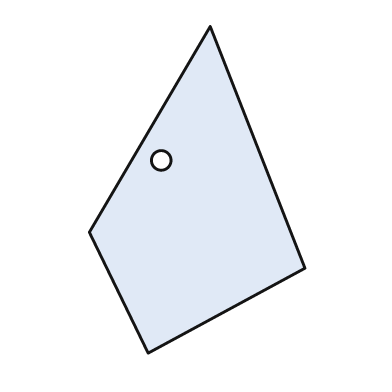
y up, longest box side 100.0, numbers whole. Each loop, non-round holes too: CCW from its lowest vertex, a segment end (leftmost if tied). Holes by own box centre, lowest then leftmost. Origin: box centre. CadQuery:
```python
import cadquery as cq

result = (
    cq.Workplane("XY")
    .moveTo(-15.0, -50.0)
    .lineTo(33.0, -24.0)
    .lineTo(4.0, 50.0)
    .lineTo(-33.0, -13.0)
    .close()
    .moveTo(-11.0, 9.0)
    .circle(3.0)
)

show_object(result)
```